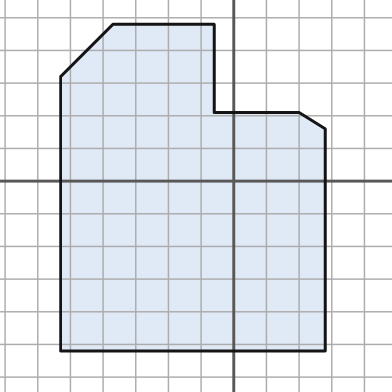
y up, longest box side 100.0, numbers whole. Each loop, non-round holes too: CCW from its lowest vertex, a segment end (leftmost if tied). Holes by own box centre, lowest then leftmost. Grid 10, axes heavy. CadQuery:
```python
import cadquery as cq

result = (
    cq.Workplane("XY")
    .moveTo(-53.0, -52.0)
    .lineTo(28.0, -52.0)
    .lineTo(28.0, 16.0)
    .lineTo(20.0, 21.0)
    .lineTo(-6.0, 21.0)
    .lineTo(-6.0, 48.0)
    .lineTo(-37.0, 48.0)
    .lineTo(-53.0, 32.0)
    .close()
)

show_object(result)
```